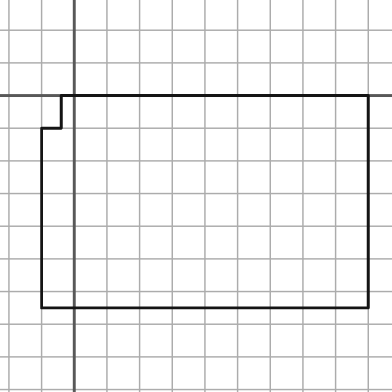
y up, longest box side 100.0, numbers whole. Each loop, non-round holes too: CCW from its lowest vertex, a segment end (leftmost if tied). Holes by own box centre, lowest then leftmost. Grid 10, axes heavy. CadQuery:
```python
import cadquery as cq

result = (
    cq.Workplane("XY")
    .moveTo(-10.0, -65.0)
    .lineTo(90.0, -65.0)
    .lineTo(90.0, 0.0)
    .lineTo(-4.0, 0.0)
    .lineTo(-4.0, -10.0)
    .lineTo(-10.0, -10.0)
    .close()
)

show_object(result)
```